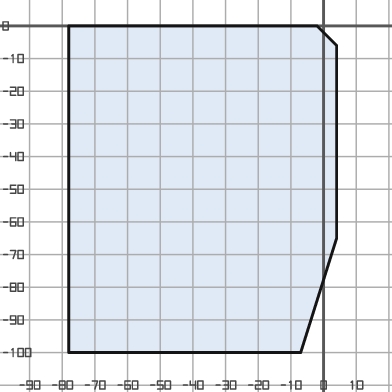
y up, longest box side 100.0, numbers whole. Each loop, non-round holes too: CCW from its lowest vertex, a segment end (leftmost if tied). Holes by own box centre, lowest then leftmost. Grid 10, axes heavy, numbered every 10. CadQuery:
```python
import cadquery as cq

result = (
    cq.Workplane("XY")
    .moveTo(-78.0, -100.0)
    .lineTo(-7.0, -100.0)
    .lineTo(4.0, -65.0)
    .lineTo(4.0, -6.0)
    .lineTo(-2.0, 0.0)
    .lineTo(-78.0, 0.0)
    .close()
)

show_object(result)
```